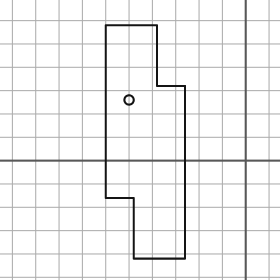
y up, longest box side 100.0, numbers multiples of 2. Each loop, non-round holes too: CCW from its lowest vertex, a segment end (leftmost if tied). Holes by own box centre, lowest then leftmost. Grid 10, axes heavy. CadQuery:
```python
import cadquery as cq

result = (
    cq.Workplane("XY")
    .moveTo(-48.0, -42.0)
    .lineTo(-26.0, -42.0)
    .lineTo(-26.0, 32.0)
    .lineTo(-38.0, 32.0)
    .lineTo(-38.0, 58.0)
    .lineTo(-60.0, 58.0)
    .lineTo(-60.0, -16.0)
    .lineTo(-48.0, -16.0)
    .close()
    .moveTo(-50.0, 26.0)
    .circle(2.0)
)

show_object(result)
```